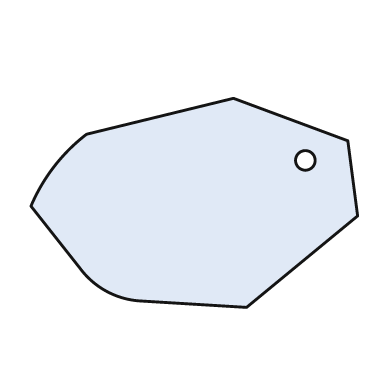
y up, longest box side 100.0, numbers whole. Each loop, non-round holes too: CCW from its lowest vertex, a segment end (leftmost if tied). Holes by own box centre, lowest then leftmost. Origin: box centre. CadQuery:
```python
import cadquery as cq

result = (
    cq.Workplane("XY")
    .moveTo(16.0, -32.0)
    .lineTo(50.0, -4.0)
    .lineTo(47.0, 19.0)
    .lineTo(12.0, 32.0)
    .lineTo(-33.0, 21.0)
    .threePointArc((-43.0, 11.0), (-50.0, -1.0))
    .lineTo(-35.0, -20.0)
    .threePointArc((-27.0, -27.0), (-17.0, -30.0))
    .close()
    .moveTo(34.0, 13.0)
    .circle(3.0)
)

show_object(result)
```